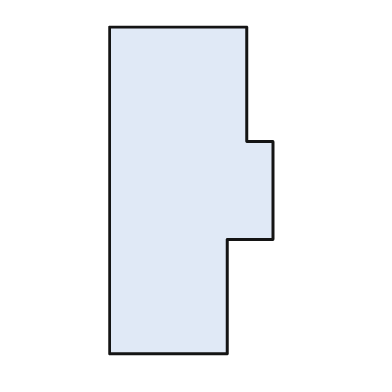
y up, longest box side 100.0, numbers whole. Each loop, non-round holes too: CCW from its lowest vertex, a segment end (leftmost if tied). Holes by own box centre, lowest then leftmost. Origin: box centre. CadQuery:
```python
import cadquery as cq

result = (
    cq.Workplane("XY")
    .moveTo(-25.0, -50.0)
    .lineTo(11.0, -50.0)
    .lineTo(11.0, -15.0)
    .lineTo(25.0, -15.0)
    .lineTo(25.0, 15.0)
    .lineTo(17.0, 15.0)
    .lineTo(17.0, 50.0)
    .lineTo(-25.0, 50.0)
    .close()
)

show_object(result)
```